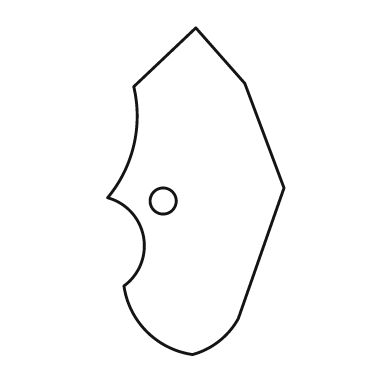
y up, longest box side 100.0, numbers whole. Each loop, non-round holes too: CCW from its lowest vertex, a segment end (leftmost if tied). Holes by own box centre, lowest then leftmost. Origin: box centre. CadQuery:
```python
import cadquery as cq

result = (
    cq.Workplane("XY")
    .moveTo(-1.0, -50.0)
    .threePointArc((7.0, -46.0), (13.0, -39.0))
    .lineTo(27.0, 1.0)
    .lineTo(15.0, 33.0)
    .lineTo(0.0, 50.0)
    .lineTo(-19.0, 32.0)
    .threePointArc((-19.0, 14.0), (-27.0, -2.0))
    .threePointArc((-16.0, -14.0), (-22.0, -29.0))
    .threePointArc((-15.0, -43.0), (-1.0, -50.0))
    .close()
    .moveTo(-10.0, -3.0)
    .circle(4.0)
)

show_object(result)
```